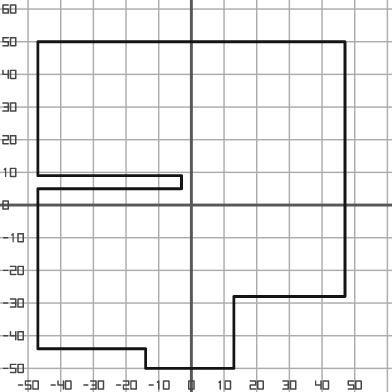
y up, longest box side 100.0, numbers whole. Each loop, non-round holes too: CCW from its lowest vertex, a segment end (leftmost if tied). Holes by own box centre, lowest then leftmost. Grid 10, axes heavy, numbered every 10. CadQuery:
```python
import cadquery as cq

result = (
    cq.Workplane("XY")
    .moveTo(-14.0, -50.0)
    .lineTo(13.0, -50.0)
    .lineTo(13.0, -28.0)
    .lineTo(47.0, -28.0)
    .lineTo(47.0, 50.0)
    .lineTo(-47.0, 50.0)
    .lineTo(-47.0, 9.0)
    .lineTo(-3.0, 9.0)
    .lineTo(-3.0, 5.0)
    .lineTo(-47.0, 5.0)
    .lineTo(-47.0, -44.0)
    .lineTo(-14.0, -44.0)
    .close()
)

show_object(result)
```